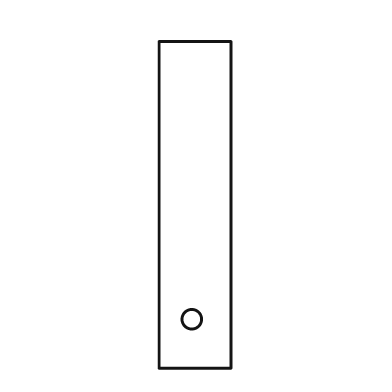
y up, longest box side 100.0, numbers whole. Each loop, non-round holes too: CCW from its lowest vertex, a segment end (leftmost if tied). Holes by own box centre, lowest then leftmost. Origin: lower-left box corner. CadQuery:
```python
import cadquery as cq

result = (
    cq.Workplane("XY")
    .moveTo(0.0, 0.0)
    .lineTo(22.0, 0.0)
    .lineTo(22.0, 100.0)
    .lineTo(0.0, 100.0)
    .close()
    .moveTo(10.0, 15.0)
    .circle(3.0)
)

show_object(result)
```